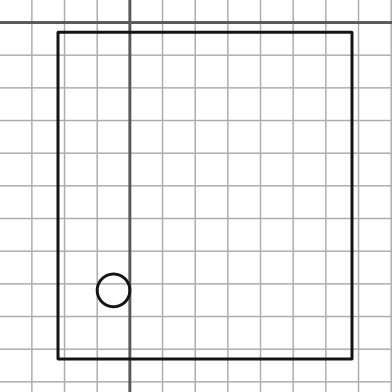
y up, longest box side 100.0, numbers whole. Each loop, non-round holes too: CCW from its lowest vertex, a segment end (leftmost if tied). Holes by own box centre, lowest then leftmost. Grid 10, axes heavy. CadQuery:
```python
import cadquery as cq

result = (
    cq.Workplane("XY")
    .moveTo(-22.0, -103.0)
    .lineTo(68.0, -103.0)
    .lineTo(68.0, -3.0)
    .lineTo(-22.0, -3.0)
    .close()
    .moveTo(-5.0, -82.0)
    .circle(5.0)
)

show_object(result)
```